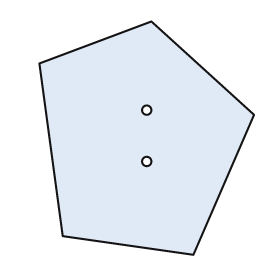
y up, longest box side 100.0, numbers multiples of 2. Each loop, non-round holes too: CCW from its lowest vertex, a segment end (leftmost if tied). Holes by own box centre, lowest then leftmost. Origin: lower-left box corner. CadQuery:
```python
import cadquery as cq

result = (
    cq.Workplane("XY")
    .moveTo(66.0, 0.0)
    .lineTo(92.0, 60.0)
    .lineTo(48.0, 100.0)
    .lineTo(0.0, 82.0)
    .lineTo(10.0, 8.0)
    .close()
    .moveTo(46.0, 40.0)
    .circle(2.0)
    .moveTo(46.0, 62.0)
    .circle(2.0)
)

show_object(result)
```